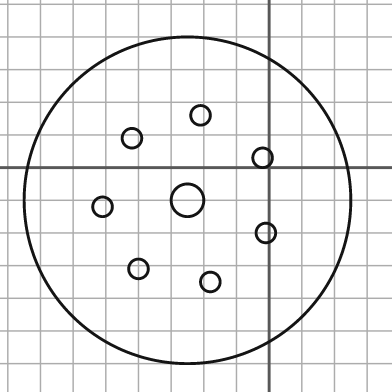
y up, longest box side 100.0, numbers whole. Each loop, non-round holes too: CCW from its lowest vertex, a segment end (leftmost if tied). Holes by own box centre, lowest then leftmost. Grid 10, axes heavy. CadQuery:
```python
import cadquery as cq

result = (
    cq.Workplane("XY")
    .moveTo(-25.0, -10.0)
    .circle(50.0)
    .moveTo(-18.0, -35.0)
    .circle(3.0)
    .moveTo(-40.0, -31.0)
    .circle(3.0)
    .moveTo(-1.0, -20.0)
    .circle(3.0)
    .moveTo(-51.0, -12.0)
    .circle(3.0)
    .moveTo(-25.0, -10.0)
    .circle(5.0)
    .moveTo(-2.0, 3.0)
    .circle(3.0)
    .moveTo(-42.0, 9.0)
    .circle(3.0)
    .moveTo(-21.0, 16.0)
    .circle(3.0)
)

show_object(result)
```